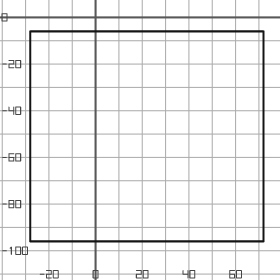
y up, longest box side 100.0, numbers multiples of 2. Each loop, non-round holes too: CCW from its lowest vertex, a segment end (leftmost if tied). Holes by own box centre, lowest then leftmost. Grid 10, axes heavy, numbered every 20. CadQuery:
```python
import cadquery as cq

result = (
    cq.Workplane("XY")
    .moveTo(-28.0, -96.0)
    .lineTo(72.0, -96.0)
    .lineTo(72.0, -6.0)
    .lineTo(-28.0, -6.0)
    .close()
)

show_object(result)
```